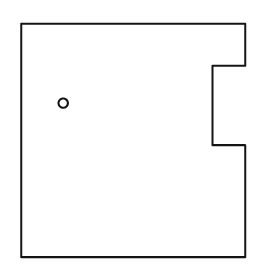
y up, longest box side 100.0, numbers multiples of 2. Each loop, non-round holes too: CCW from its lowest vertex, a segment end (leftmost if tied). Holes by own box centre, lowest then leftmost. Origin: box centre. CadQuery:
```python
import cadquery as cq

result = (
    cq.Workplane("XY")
    .moveTo(-48.0, -50.0)
    .lineTo(48.0, -50.0)
    .lineTo(48.0, -2.0)
    .lineTo(34.0, -2.0)
    .lineTo(34.0, 32.0)
    .lineTo(48.0, 32.0)
    .lineTo(48.0, 50.0)
    .lineTo(-48.0, 50.0)
    .close()
    .moveTo(-30.0, 16.0)
    .circle(2.0)
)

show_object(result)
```